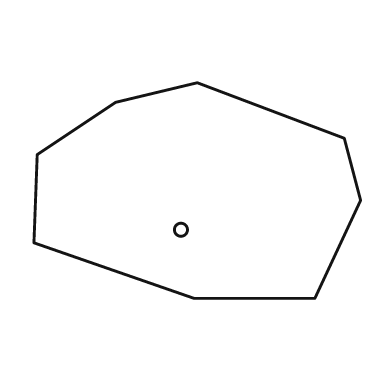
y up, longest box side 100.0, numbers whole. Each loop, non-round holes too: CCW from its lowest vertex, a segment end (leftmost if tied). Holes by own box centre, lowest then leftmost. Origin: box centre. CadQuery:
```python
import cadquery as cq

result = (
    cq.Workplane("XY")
    .moveTo(-1.0, -33.0)
    .lineTo(36.0, -33.0)
    .lineTo(50.0, -3.0)
    .lineTo(45.0, 16.0)
    .lineTo(0.0, 33.0)
    .lineTo(-25.0, 27.0)
    .lineTo(-49.0, 11.0)
    .lineTo(-50.0, -16.0)
    .close()
    .moveTo(-5.0, -12.0)
    .circle(2.0)
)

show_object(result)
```